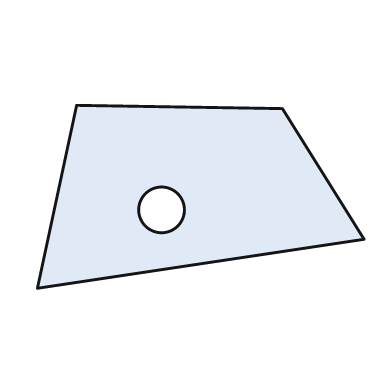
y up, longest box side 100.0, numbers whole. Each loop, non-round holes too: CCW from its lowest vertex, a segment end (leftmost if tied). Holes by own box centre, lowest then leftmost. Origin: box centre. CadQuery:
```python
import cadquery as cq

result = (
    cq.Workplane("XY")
    .moveTo(-50.0, -28.0)
    .lineTo(50.0, -13.0)
    .lineTo(25.0, 27.0)
    .lineTo(-38.0, 28.0)
    .close()
    .moveTo(-12.0, -4.0)
    .circle(7.0)
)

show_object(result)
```